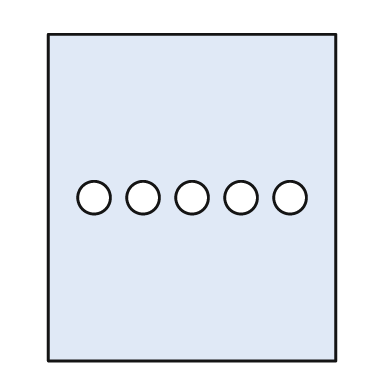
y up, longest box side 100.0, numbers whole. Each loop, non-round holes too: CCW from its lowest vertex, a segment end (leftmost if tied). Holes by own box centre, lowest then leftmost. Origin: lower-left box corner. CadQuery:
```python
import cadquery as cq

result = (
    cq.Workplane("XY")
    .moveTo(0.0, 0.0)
    .lineTo(88.0, 0.0)
    .lineTo(88.0, 100.0)
    .lineTo(0.0, 100.0)
    .close()
    .moveTo(14.0, 50.0)
    .circle(5.0)
    .moveTo(29.0, 50.0)
    .circle(5.0)
    .moveTo(44.0, 50.0)
    .circle(5.0)
    .moveTo(59.0, 50.0)
    .circle(5.0)
    .moveTo(74.0, 50.0)
    .circle(5.0)
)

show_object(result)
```